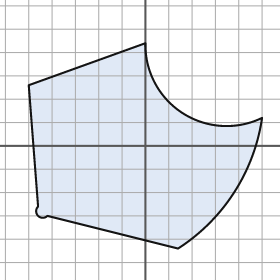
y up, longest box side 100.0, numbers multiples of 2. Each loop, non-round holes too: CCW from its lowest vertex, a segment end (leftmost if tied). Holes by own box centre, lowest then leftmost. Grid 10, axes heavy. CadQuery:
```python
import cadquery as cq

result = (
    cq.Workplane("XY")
    .moveTo(14.0, -44.0)
    .threePointArc((38.0, -20.0), (50.0, 12.0))
    .threePointArc((16.0, 14.0), (0.0, 44.0))
    .lineTo(-50.0, 26.0)
    .lineTo(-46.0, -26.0)
    .threePointArc((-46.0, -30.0), (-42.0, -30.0))
    .close()
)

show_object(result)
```